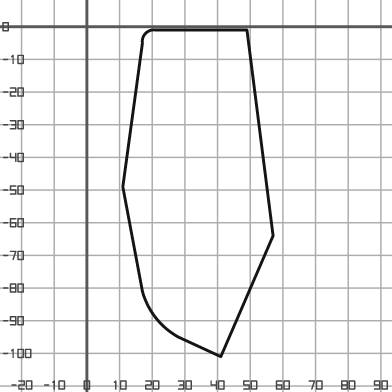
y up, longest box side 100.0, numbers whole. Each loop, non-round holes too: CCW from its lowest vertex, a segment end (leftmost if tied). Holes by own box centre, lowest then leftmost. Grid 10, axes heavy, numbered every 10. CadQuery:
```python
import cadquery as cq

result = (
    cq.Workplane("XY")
    .moveTo(41.0, -101.0)
    .lineTo(57.0, -64.0)
    .lineTo(49.0, -1.0)
    .lineTo(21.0, -1.0)
    .threePointArc((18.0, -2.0), (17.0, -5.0))
    .lineTo(11.0, -49.0)
    .lineTo(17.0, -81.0)
    .threePointArc((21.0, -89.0), (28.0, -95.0))
    .close()
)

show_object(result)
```